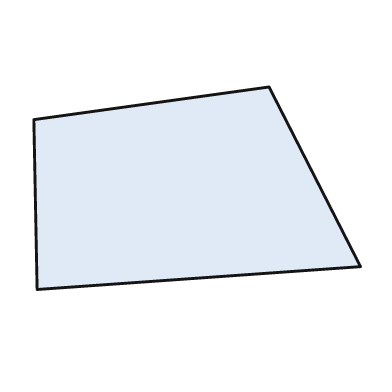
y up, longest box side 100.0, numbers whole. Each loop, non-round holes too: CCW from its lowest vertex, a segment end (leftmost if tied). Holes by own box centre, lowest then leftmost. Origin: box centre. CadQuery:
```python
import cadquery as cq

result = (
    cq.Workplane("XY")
    .moveTo(-49.0, -31.0)
    .lineTo(50.0, -24.0)
    .lineTo(22.0, 31.0)
    .lineTo(-50.0, 21.0)
    .close()
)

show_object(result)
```